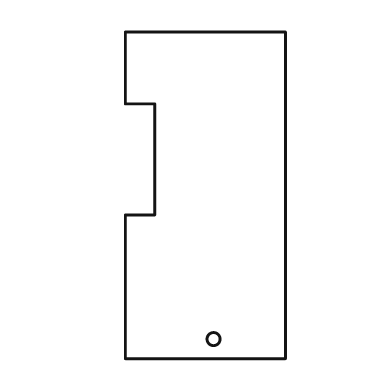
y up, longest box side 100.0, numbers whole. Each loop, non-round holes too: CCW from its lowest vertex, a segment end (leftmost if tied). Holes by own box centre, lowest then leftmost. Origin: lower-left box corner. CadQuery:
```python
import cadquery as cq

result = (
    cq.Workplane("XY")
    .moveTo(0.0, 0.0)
    .lineTo(49.0, 0.0)
    .lineTo(49.0, 100.0)
    .lineTo(0.0, 100.0)
    .lineTo(0.0, 78.0)
    .lineTo(9.0, 78.0)
    .lineTo(9.0, 44.0)
    .lineTo(0.0, 44.0)
    .close()
    .moveTo(27.0, 6.0)
    .circle(2.0)
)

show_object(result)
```